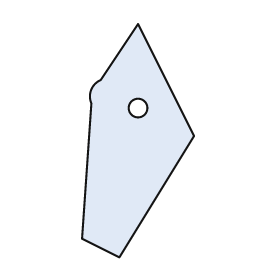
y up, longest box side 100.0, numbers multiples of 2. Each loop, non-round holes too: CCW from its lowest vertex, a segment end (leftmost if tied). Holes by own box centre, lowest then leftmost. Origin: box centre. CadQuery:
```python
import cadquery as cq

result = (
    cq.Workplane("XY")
    .moveTo(-8.0, -50.0)
    .lineTo(24.0, 2.0)
    .lineTo(0.0, 50.0)
    .lineTo(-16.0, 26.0)
    .threePointArc((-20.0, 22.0), (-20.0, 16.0))
    .lineTo(-24.0, -42.0)
    .close()
    .moveTo(0.0, 14.0)
    .circle(4.0)
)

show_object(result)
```